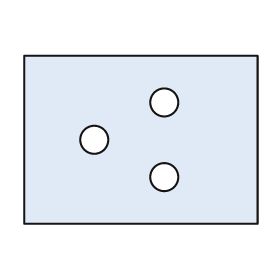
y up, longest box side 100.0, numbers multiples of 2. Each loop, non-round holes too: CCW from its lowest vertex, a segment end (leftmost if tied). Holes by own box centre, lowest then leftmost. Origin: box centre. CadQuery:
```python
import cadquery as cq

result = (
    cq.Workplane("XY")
    .moveTo(-50.0, -36.0)
    .lineTo(50.0, -36.0)
    .lineTo(50.0, 36.0)
    .lineTo(-50.0, 36.0)
    .close()
    .moveTo(10.0, -16.0)
    .circle(6.0)
    .moveTo(-20.0, 0.0)
    .circle(6.0)
    .moveTo(10.0, 16.0)
    .circle(6.0)
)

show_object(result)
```